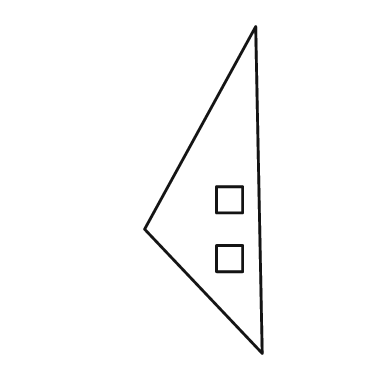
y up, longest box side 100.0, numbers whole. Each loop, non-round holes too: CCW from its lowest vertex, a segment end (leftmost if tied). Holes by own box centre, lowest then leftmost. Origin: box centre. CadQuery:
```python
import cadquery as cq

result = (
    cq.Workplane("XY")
    .moveTo(18.0, -50.0)
    .lineTo(16.0, 50.0)
    .lineTo(-18.0, -12.0)
    .close()
    .moveTo(4.0, -25.0)
    .lineTo(12.0, -25.0)
    .lineTo(12.0, -17.0)
    .lineTo(4.0, -17.0)
    .close()
    .moveTo(4.0, -7.0)
    .lineTo(12.0, -7.0)
    .lineTo(12.0, 1.0)
    .lineTo(4.0, 1.0)
    .close()
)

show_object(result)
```